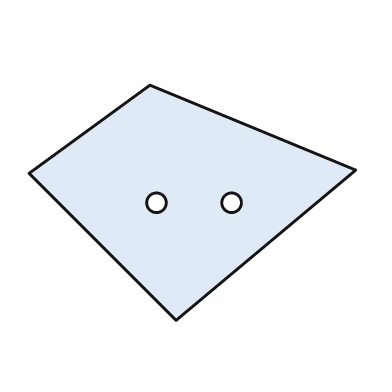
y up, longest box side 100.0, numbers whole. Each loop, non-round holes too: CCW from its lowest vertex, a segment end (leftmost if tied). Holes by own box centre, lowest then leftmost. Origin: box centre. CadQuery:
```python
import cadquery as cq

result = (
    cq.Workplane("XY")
    .moveTo(-5.0, -36.0)
    .lineTo(50.0, 10.0)
    .lineTo(-13.0, 36.0)
    .lineTo(-50.0, 9.0)
    .close()
    .moveTo(-11.0, 0.0)
    .circle(3.0)
    .moveTo(12.0, 0.0)
    .circle(3.0)
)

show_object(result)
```